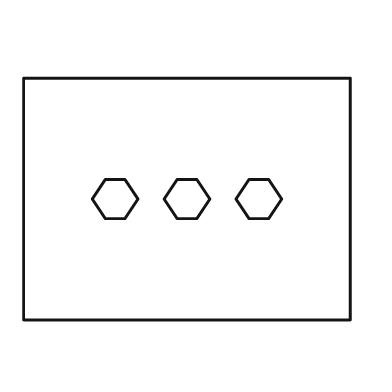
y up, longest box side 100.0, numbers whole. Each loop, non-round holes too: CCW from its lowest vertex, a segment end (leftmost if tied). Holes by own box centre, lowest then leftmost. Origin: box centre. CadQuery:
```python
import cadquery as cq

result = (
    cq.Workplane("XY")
    .moveTo(-50.0, -37.0)
    .lineTo(50.0, -37.0)
    .lineTo(50.0, 37.0)
    .lineTo(-50.0, 37.0)
    .close()
    .moveTo(-25.0, -6.0)
    .lineTo(-19.0, -6.0)
    .lineTo(-15.0, 0.0)
    .lineTo(-19.0, 6.0)
    .lineTo(-25.0, 6.0)
    .lineTo(-29.0, 0.0)
    .close()
    .moveTo(-3.0, -6.0)
    .lineTo(3.0, -6.0)
    .lineTo(7.0, 0.0)
    .lineTo(3.0, 6.0)
    .lineTo(-3.0, 6.0)
    .lineTo(-7.0, 0.0)
    .close()
    .moveTo(19.0, -6.0)
    .lineTo(25.0, -6.0)
    .lineTo(29.0, 0.0)
    .lineTo(25.0, 6.0)
    .lineTo(19.0, 6.0)
    .lineTo(15.0, 0.0)
    .close()
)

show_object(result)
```